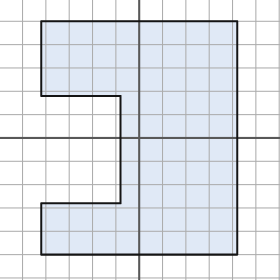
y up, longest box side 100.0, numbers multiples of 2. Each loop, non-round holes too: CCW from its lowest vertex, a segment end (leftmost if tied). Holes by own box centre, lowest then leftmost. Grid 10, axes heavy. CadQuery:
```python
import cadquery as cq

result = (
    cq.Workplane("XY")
    .moveTo(-42.0, -50.0)
    .lineTo(42.0, -50.0)
    .lineTo(42.0, 50.0)
    .lineTo(-42.0, 50.0)
    .lineTo(-42.0, 18.0)
    .lineTo(-8.0, 18.0)
    .lineTo(-8.0, -28.0)
    .lineTo(-42.0, -28.0)
    .close()
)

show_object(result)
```